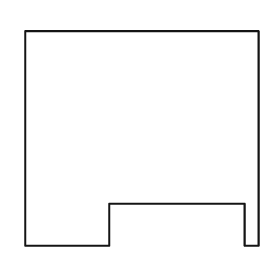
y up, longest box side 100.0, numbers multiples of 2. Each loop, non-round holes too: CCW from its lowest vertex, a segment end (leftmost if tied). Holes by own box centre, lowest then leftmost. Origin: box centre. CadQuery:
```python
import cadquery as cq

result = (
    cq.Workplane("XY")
    .moveTo(-50.0, -46.0)
    .lineTo(-14.0, -46.0)
    .lineTo(-14.0, -28.0)
    .lineTo(44.0, -28.0)
    .lineTo(44.0, -46.0)
    .lineTo(50.0, -46.0)
    .lineTo(50.0, 46.0)
    .lineTo(-50.0, 46.0)
    .close()
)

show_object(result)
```